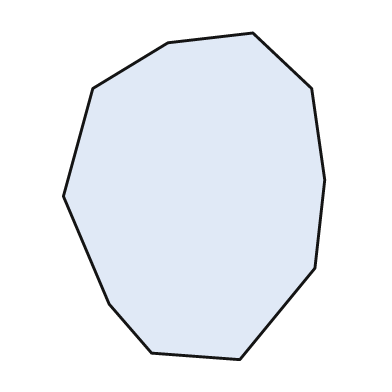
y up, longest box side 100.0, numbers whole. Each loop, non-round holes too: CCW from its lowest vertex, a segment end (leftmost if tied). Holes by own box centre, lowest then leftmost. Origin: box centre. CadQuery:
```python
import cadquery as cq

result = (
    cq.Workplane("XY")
    .moveTo(14.0, -50.0)
    .lineTo(37.0, -22.0)
    .lineTo(40.0, 5.0)
    .lineTo(36.0, 33.0)
    .lineTo(18.0, 50.0)
    .lineTo(-8.0, 47.0)
    .lineTo(-31.0, 33.0)
    .lineTo(-40.0, 0.0)
    .lineTo(-26.0, -33.0)
    .lineTo(-13.0, -48.0)
    .close()
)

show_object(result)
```